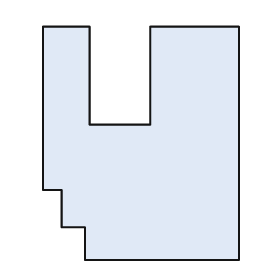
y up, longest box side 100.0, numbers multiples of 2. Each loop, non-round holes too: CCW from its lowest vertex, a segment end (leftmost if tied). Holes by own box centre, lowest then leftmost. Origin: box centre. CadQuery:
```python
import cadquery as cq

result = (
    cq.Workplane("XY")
    .moveTo(-24.0, -50.0)
    .lineTo(42.0, -50.0)
    .lineTo(42.0, 50.0)
    .lineTo(4.0, 50.0)
    .lineTo(4.0, 8.0)
    .lineTo(-22.0, 8.0)
    .lineTo(-22.0, 50.0)
    .lineTo(-42.0, 50.0)
    .lineTo(-42.0, -20.0)
    .lineTo(-34.0, -20.0)
    .lineTo(-34.0, -36.0)
    .lineTo(-24.0, -36.0)
    .close()
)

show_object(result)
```